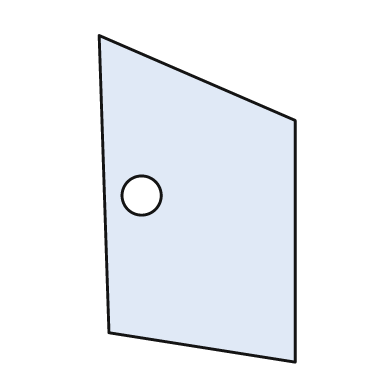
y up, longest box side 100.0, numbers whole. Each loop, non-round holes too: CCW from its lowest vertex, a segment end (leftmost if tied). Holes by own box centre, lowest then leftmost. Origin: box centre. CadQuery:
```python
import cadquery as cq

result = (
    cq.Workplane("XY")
    .moveTo(30.0, -50.0)
    .lineTo(30.0, 24.0)
    .lineTo(-30.0, 50.0)
    .lineTo(-27.0, -41.0)
    .close()
    .moveTo(-17.0, 1.0)
    .circle(6.0)
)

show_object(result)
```